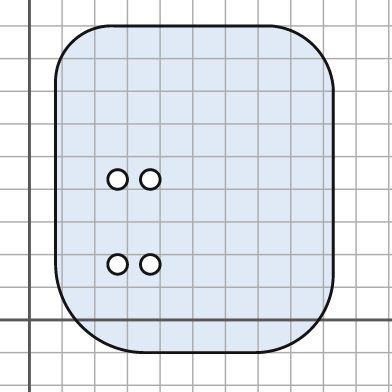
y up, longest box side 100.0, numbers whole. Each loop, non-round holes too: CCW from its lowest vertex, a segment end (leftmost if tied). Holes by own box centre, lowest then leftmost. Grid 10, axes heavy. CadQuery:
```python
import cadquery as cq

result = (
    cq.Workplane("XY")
    .moveTo(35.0, -10.0)
    .lineTo(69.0, -10.0)
    .threePointArc((86.0, -3.0), (93.0, 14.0))
    .lineTo(93.0, 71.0)
    .threePointArc((87.0, 84.0), (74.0, 90.0))
    .lineTo(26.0, 90.0)
    .threePointArc((13.0, 85.0), (8.0, 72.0))
    .lineTo(8.0, 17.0)
    .threePointArc((16.0, -2.0), (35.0, -10.0))
    .close()
    .moveTo(27.0, 17.0)
    .circle(3.0)
    .moveTo(37.0, 17.0)
    .circle(3.0)
    .moveTo(27.0, 43.0)
    .circle(3.0)
    .moveTo(37.0, 43.0)
    .circle(3.0)
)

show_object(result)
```